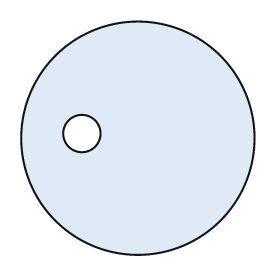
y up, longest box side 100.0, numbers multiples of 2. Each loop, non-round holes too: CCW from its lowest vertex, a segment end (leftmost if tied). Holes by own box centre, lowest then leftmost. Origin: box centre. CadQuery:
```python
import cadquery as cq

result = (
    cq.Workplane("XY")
    .moveTo(0.0, 0.0)
    .circle(50.0)
    .moveTo(-24.0, 2.0)
    .circle(8.0)
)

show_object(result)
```